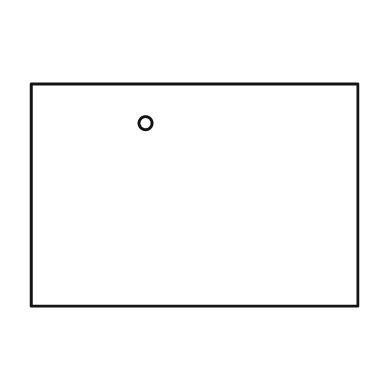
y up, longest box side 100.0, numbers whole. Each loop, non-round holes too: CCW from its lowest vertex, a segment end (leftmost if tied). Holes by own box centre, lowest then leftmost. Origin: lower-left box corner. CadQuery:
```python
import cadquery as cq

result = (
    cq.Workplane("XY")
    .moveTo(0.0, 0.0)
    .lineTo(100.0, 0.0)
    .lineTo(100.0, 68.0)
    .lineTo(0.0, 68.0)
    .close()
    .moveTo(35.0, 56.0)
    .circle(2.0)
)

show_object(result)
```